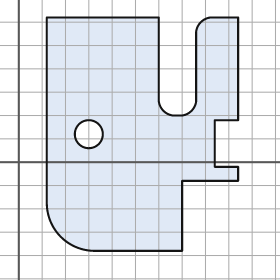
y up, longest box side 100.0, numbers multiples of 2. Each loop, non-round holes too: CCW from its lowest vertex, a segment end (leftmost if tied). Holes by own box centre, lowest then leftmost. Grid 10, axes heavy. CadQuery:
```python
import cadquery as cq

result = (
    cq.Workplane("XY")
    .moveTo(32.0, -38.0)
    .lineTo(70.0, -38.0)
    .lineTo(70.0, -8.0)
    .lineTo(94.0, -8.0)
    .lineTo(94.0, -2.0)
    .lineTo(84.0, -2.0)
    .lineTo(84.0, 18.0)
    .lineTo(94.0, 18.0)
    .lineTo(94.0, 62.0)
    .lineTo(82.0, 62.0)
    .threePointArc((78.0, 60.0), (76.0, 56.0))
    .lineTo(76.0, 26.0)
    .threePointArc((74.0, 22.0), (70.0, 20.0))
    .lineTo(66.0, 20.0)
    .threePointArc((62.0, 22.0), (60.0, 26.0))
    .lineTo(60.0, 62.0)
    .lineTo(12.0, 62.0)
    .lineTo(12.0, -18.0)
    .threePointArc((18.0, -32.0), (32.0, -38.0))
    .close()
    .moveTo(30.0, 12.0)
    .circle(6.0)
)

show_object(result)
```